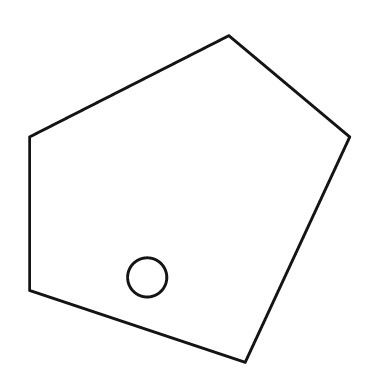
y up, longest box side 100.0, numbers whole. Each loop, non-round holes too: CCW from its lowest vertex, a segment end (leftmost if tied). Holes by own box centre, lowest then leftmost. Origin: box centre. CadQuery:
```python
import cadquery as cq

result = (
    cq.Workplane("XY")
    .moveTo(17.0, -50.0)
    .lineTo(49.0, 19.0)
    .lineTo(12.0, 50.0)
    .lineTo(-49.0, 19.0)
    .lineTo(-49.0, -28.0)
    .close()
    .moveTo(-13.0, -24.0)
    .circle(6.0)
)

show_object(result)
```